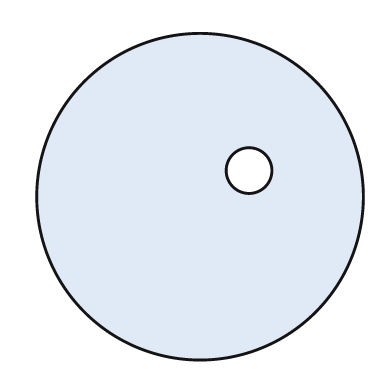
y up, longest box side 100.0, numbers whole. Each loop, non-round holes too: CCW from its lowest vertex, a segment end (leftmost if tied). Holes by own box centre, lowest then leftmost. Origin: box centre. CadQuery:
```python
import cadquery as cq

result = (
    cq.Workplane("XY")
    .moveTo(0.0, 0.0)
    .circle(50.0)
    .moveTo(15.0, 8.0)
    .circle(7.0)
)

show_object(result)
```